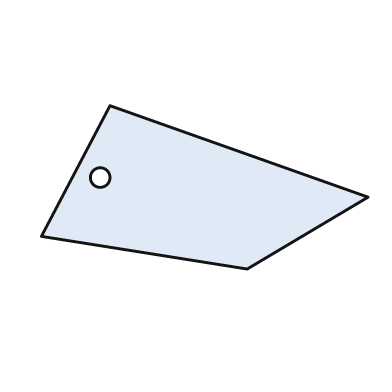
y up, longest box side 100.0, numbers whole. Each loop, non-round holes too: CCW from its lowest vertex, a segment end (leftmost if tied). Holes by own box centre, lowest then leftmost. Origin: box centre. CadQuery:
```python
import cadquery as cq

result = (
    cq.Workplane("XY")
    .moveTo(13.0, -25.0)
    .lineTo(50.0, -3.0)
    .lineTo(-29.0, 25.0)
    .lineTo(-50.0, -15.0)
    .close()
    .moveTo(-32.0, 3.0)
    .circle(3.0)
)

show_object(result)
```